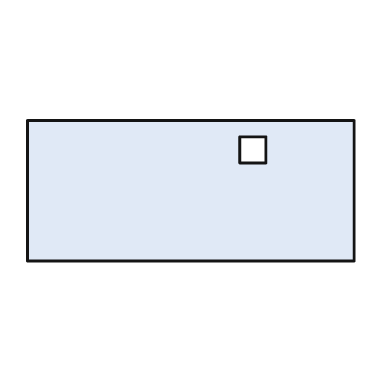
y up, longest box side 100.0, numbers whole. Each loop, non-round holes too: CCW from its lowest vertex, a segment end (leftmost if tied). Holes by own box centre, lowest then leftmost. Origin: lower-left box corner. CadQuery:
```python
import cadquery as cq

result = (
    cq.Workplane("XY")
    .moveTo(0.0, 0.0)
    .lineTo(100.0, 0.0)
    .lineTo(100.0, 43.0)
    .lineTo(0.0, 43.0)
    .close()
    .moveTo(65.0, 30.0)
    .lineTo(73.0, 30.0)
    .lineTo(73.0, 38.0)
    .lineTo(65.0, 38.0)
    .close()
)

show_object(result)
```